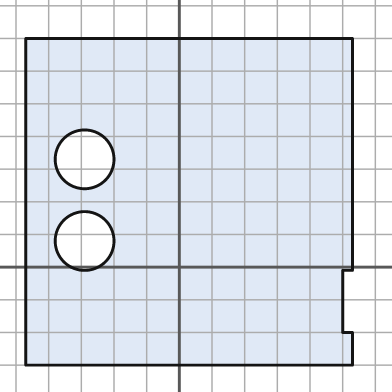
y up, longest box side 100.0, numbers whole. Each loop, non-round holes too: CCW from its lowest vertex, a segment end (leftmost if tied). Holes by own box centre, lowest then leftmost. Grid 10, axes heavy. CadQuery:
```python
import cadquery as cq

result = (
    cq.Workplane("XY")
    .moveTo(-47.0, -30.0)
    .lineTo(53.0, -30.0)
    .lineTo(53.0, -20.0)
    .lineTo(50.0, -20.0)
    .lineTo(50.0, -1.0)
    .lineTo(53.0, -1.0)
    .lineTo(53.0, 70.0)
    .lineTo(-47.0, 70.0)
    .close()
    .moveTo(-29.0, 8.0)
    .circle(9.0)
    .moveTo(-29.0, 33.0)
    .circle(9.0)
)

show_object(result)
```